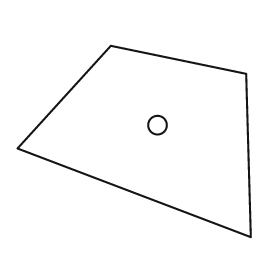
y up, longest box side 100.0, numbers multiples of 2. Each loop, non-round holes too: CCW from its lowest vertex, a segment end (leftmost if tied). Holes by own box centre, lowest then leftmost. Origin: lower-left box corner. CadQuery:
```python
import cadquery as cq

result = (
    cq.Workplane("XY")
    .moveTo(100.0, 0.0)
    .lineTo(98.0, 70.0)
    .lineTo(40.0, 82.0)
    .lineTo(0.0, 38.0)
    .close()
    .moveTo(60.0, 48.0)
    .circle(4.0)
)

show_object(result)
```